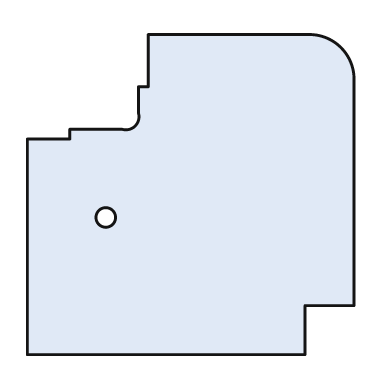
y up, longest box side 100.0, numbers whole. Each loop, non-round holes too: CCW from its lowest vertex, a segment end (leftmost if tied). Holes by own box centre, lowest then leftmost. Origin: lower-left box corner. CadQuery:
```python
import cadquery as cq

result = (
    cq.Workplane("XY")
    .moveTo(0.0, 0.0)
    .lineTo(85.0, 0.0)
    .lineTo(85.0, 15.0)
    .lineTo(100.0, 15.0)
    .lineTo(100.0, 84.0)
    .threePointArc((96.0, 94.0), (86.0, 98.0))
    .lineTo(37.0, 98.0)
    .lineTo(37.0, 82.0)
    .lineTo(34.0, 82.0)
    .lineTo(34.0, 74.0)
    .threePointArc((33.0, 70.0), (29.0, 69.0))
    .lineTo(13.0, 69.0)
    .lineTo(13.0, 66.0)
    .lineTo(0.0, 66.0)
    .close()
    .moveTo(24.0, 42.0)
    .circle(3.0)
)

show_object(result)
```